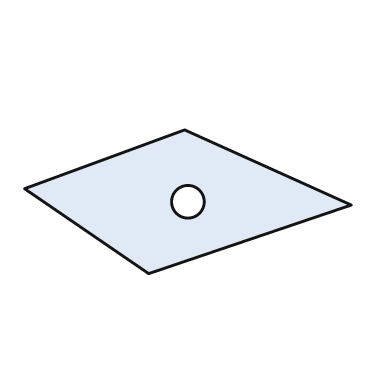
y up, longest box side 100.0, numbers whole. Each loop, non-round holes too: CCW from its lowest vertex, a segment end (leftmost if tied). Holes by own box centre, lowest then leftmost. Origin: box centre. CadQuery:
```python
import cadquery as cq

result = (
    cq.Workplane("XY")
    .moveTo(-12.0, -22.0)
    .lineTo(50.0, -1.0)
    .lineTo(-1.0, 22.0)
    .lineTo(-50.0, 4.0)
    .close()
    .moveTo(0.0, 0.0)
    .circle(5.0)
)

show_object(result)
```